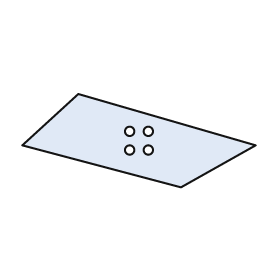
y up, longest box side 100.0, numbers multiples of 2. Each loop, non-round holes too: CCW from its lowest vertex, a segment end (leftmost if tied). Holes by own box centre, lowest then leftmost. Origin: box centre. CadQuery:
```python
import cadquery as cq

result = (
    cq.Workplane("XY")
    .moveTo(18.0, -20.0)
    .lineTo(50.0, -2.0)
    .lineTo(-26.0, 20.0)
    .lineTo(-50.0, -2.0)
    .close()
    .moveTo(-4.0, -4.0)
    .circle(2.0)
    .moveTo(4.0, -4.0)
    .circle(2.0)
    .moveTo(-4.0, 4.0)
    .circle(2.0)
    .moveTo(4.0, 4.0)
    .circle(2.0)
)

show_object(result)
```